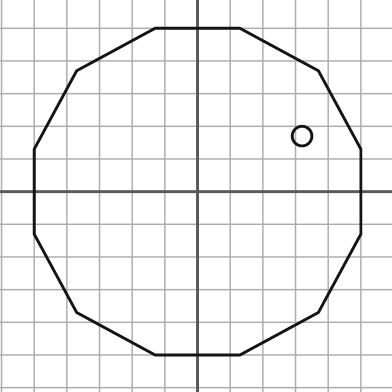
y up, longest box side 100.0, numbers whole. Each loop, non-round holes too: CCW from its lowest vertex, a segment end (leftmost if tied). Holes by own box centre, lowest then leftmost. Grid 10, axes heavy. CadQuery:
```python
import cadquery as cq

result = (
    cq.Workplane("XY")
    .moveTo(-13.0, -50.0)
    .lineTo(13.0, -50.0)
    .lineTo(37.0, -37.0)
    .lineTo(50.0, -13.0)
    .lineTo(50.0, 13.0)
    .lineTo(37.0, 37.0)
    .lineTo(13.0, 50.0)
    .lineTo(-13.0, 50.0)
    .lineTo(-37.0, 37.0)
    .lineTo(-50.0, 13.0)
    .lineTo(-50.0, -13.0)
    .lineTo(-37.0, -37.0)
    .close()
    .moveTo(32.0, 17.0)
    .circle(3.0)
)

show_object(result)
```